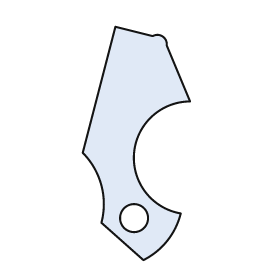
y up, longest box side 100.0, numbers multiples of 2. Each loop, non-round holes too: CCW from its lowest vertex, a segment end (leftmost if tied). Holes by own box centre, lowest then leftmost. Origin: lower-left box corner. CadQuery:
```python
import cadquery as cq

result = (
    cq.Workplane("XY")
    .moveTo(26.0, 0.0)
    .threePointArc((36.0, 8.0), (42.0, 20.0))
    .threePointArc((22.0, 46.0), (46.0, 68.0))
    .lineTo(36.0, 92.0)
    .threePointArc((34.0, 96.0), (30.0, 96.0))
    .lineTo(14.0, 100.0)
    .lineTo(0.0, 46.0)
    .threePointArc((8.0, 32.0), (8.0, 16.0))
    .close()
    .moveTo(22.0, 18.0)
    .circle(6.0)
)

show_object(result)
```